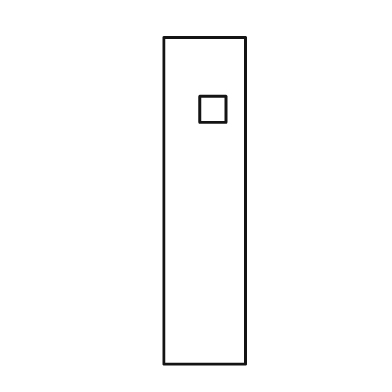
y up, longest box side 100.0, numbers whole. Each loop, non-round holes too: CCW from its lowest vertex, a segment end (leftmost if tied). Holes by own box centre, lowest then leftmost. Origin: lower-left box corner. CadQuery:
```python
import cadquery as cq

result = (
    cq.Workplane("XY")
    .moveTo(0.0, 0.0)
    .lineTo(25.0, 0.0)
    .lineTo(25.0, 100.0)
    .lineTo(0.0, 100.0)
    .close()
    .moveTo(11.0, 74.0)
    .lineTo(19.0, 74.0)
    .lineTo(19.0, 82.0)
    .lineTo(11.0, 82.0)
    .close()
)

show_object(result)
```